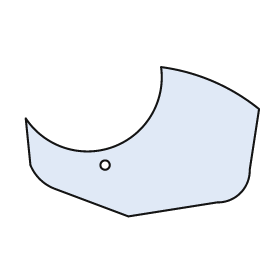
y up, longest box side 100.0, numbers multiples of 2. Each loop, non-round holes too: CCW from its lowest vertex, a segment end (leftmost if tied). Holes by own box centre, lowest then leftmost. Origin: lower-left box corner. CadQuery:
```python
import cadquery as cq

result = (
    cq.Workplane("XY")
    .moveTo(44.0, 0.0)
    .lineTo(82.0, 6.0)
    .threePointArc((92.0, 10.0), (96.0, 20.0))
    .lineTo(100.0, 46.0)
    .threePointArc((80.0, 58.0), (58.0, 64.0))
    .threePointArc((38.0, 30.0), (0.0, 42.0))
    .lineTo(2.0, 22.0)
    .threePointArc((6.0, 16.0), (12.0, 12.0))
    .close()
    .moveTo(34.0, 22.0)
    .circle(2.0)
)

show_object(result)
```